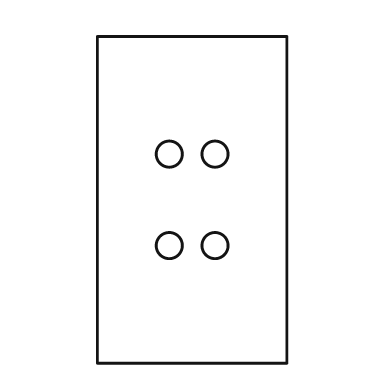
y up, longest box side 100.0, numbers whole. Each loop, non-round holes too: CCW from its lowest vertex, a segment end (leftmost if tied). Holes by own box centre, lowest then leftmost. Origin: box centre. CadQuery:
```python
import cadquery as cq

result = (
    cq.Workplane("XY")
    .moveTo(-29.0, -50.0)
    .lineTo(29.0, -50.0)
    .lineTo(29.0, 50.0)
    .lineTo(-29.0, 50.0)
    .close()
    .moveTo(-7.0, -14.0)
    .circle(4.0)
    .moveTo(7.0, -14.0)
    .circle(4.0)
    .moveTo(-7.0, 14.0)
    .circle(4.0)
    .moveTo(7.0, 14.0)
    .circle(4.0)
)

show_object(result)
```